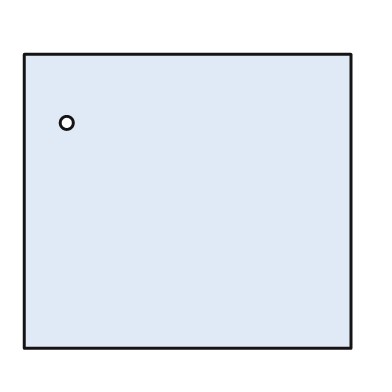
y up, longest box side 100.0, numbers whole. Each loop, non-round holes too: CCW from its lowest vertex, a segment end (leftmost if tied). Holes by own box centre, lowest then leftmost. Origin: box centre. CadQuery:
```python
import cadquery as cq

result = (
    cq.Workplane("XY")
    .moveTo(-50.0, -45.0)
    .lineTo(50.0, -45.0)
    .lineTo(50.0, 45.0)
    .lineTo(-50.0, 45.0)
    .close()
    .moveTo(-37.0, 24.0)
    .circle(2.0)
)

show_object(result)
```